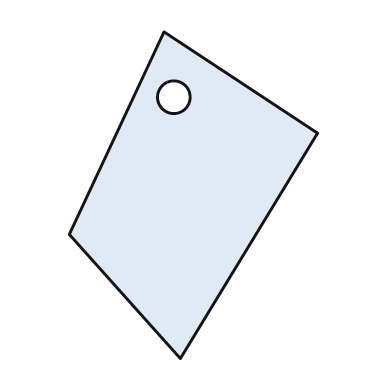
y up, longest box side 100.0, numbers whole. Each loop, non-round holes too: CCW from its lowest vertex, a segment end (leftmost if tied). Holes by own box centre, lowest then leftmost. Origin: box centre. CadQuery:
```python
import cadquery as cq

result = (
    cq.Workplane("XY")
    .moveTo(-4.0, -50.0)
    .lineTo(38.0, 19.0)
    .lineTo(-9.0, 50.0)
    .lineTo(-38.0, -12.0)
    .close()
    .moveTo(-6.0, 30.0)
    .circle(5.0)
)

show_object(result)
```